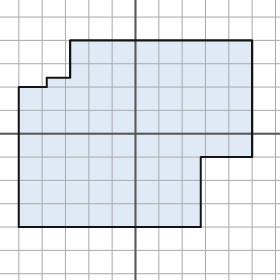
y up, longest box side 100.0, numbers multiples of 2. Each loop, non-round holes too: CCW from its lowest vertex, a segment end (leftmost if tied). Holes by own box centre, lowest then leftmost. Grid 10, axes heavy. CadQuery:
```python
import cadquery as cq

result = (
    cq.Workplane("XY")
    .moveTo(-50.0, -40.0)
    .lineTo(28.0, -40.0)
    .lineTo(28.0, -10.0)
    .lineTo(50.0, -10.0)
    .lineTo(50.0, 40.0)
    .lineTo(-28.0, 40.0)
    .lineTo(-28.0, 24.0)
    .lineTo(-38.0, 24.0)
    .lineTo(-38.0, 20.0)
    .lineTo(-50.0, 20.0)
    .close()
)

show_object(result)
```